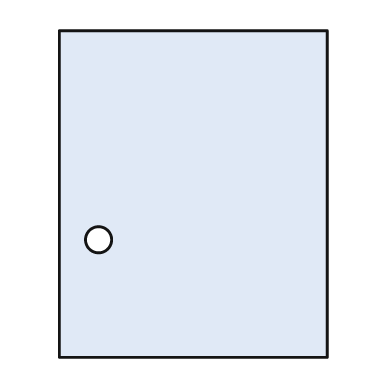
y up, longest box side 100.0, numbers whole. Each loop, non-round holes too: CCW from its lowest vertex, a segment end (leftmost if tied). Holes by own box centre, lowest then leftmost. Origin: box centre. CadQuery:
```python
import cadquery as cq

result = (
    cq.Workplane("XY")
    .moveTo(-41.0, -50.0)
    .lineTo(41.0, -50.0)
    .lineTo(41.0, 50.0)
    .lineTo(-41.0, 50.0)
    .close()
    .moveTo(-29.0, -14.0)
    .circle(4.0)
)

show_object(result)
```